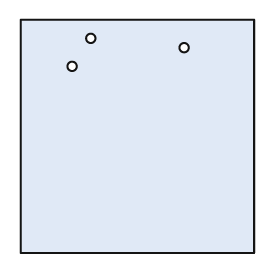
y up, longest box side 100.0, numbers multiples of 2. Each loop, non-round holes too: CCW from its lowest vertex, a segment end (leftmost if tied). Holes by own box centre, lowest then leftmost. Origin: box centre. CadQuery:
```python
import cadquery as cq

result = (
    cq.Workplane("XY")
    .moveTo(-50.0, -50.0)
    .lineTo(50.0, -50.0)
    .lineTo(50.0, 50.0)
    .lineTo(-50.0, 50.0)
    .close()
    .moveTo(-28.0, 30.0)
    .circle(2.0)
    .moveTo(20.0, 38.0)
    .circle(2.0)
    .moveTo(-20.0, 42.0)
    .circle(2.0)
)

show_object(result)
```